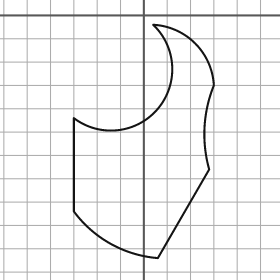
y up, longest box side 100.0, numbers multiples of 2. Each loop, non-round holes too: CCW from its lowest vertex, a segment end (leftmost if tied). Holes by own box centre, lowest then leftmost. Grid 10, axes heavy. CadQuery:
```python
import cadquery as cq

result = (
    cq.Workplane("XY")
    .moveTo(6.0, -104.0)
    .lineTo(28.0, -66.0)
    .threePointArc((26.0, -48.0), (30.0, -30.0))
    .threePointArc((22.0, -12.0), (4.0, -4.0))
    .threePointArc((6.0, -40.0), (-30.0, -44.0))
    .lineTo(-30.0, -84.0)
    .threePointArc((-14.0, -98.0), (6.0, -104.0))
    .close()
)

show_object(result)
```